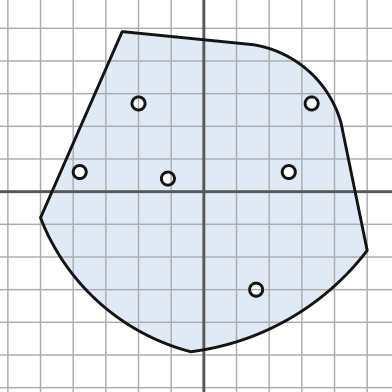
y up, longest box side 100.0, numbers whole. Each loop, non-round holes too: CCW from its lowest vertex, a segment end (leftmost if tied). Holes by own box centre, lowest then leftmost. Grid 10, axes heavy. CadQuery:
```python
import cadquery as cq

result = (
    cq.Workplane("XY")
    .moveTo(-4.0, -49.0)
    .threePointArc((26.0, -39.0), (50.0, -18.0))
    .lineTo(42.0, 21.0)
    .threePointArc((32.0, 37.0), (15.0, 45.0))
    .lineTo(-25.0, 49.0)
    .lineTo(-50.0, -8.0)
    .threePointArc((-32.0, -34.0), (-4.0, -49.0))
    .close()
    .moveTo(16.0, -30.0)
    .circle(2.0)
    .moveTo(-11.0, 4.0)
    .circle(2.0)
    .moveTo(-38.0, 6.0)
    .circle(2.0)
    .moveTo(26.0, 6.0)
    .circle(2.0)
    .moveTo(-20.0, 27.0)
    .circle(2.0)
    .moveTo(33.0, 27.0)
    .circle(2.0)
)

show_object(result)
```